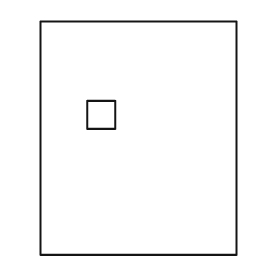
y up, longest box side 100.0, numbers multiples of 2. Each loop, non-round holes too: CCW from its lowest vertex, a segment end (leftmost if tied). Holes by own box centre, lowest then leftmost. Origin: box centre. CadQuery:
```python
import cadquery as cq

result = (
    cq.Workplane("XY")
    .moveTo(-42.0, -50.0)
    .lineTo(42.0, -50.0)
    .lineTo(42.0, 50.0)
    .lineTo(-42.0, 50.0)
    .close()
    .moveTo(-22.0, 4.0)
    .lineTo(-10.0, 4.0)
    .lineTo(-10.0, 16.0)
    .lineTo(-22.0, 16.0)
    .close()
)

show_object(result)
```